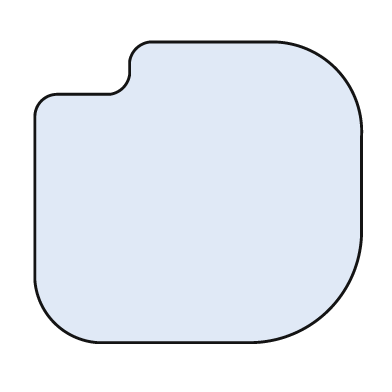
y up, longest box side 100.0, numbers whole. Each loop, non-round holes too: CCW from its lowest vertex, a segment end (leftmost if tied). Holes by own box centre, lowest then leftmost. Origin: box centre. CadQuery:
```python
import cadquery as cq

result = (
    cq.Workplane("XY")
    .moveTo(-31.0, -46.0)
    .lineTo(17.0, -46.0)
    .threePointArc((40.0, -36.0), (50.0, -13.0))
    .lineTo(50.0, 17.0)
    .threePointArc((42.0, 38.0), (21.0, 46.0))
    .lineTo(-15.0, 46.0)
    .threePointArc((-19.0, 44.0), (-21.0, 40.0))
    .lineTo(-21.0, 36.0)
    .threePointArc((-23.0, 32.0), (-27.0, 30.0))
    .lineTo(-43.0, 30.0)
    .threePointArc((-48.0, 28.0), (-50.0, 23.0))
    .lineTo(-50.0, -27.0)
    .threePointArc((-44.0, -40.0), (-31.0, -46.0))
    .close()
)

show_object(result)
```